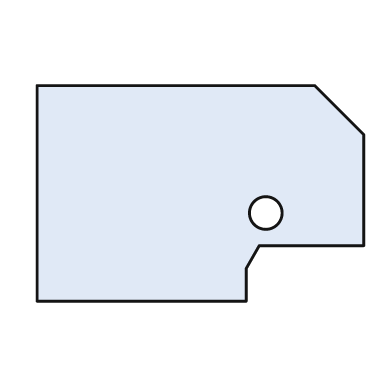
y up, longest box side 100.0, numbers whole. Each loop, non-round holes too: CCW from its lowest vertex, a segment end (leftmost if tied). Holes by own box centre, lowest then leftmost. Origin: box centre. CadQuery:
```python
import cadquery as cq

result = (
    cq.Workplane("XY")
    .moveTo(-50.0, -33.0)
    .lineTo(14.0, -33.0)
    .lineTo(14.0, -23.0)
    .lineTo(18.0, -16.0)
    .lineTo(50.0, -16.0)
    .lineTo(50.0, 18.0)
    .lineTo(35.0, 33.0)
    .lineTo(-50.0, 33.0)
    .close()
    .moveTo(20.0, -6.0)
    .circle(5.0)
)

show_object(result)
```